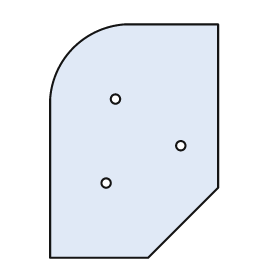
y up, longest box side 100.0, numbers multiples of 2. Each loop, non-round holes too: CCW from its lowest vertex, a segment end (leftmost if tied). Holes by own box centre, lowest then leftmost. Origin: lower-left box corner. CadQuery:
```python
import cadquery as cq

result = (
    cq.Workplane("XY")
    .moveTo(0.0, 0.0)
    .lineTo(42.0, 0.0)
    .lineTo(72.0, 30.0)
    .lineTo(72.0, 100.0)
    .lineTo(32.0, 100.0)
    .threePointArc((10.0, 90.0), (0.0, 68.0))
    .close()
    .moveTo(24.0, 32.0)
    .circle(2.0)
    .moveTo(56.0, 48.0)
    .circle(2.0)
    .moveTo(28.0, 68.0)
    .circle(2.0)
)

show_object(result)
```